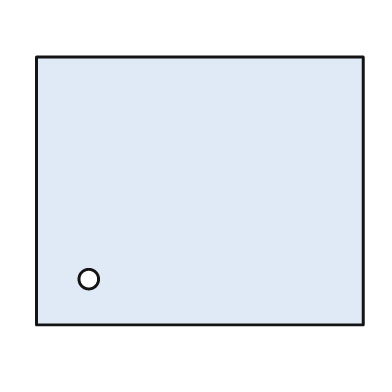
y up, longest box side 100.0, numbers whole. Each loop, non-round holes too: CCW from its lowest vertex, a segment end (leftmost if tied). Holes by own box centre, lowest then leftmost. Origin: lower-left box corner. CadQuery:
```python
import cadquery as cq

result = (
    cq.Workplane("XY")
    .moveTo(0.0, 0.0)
    .lineTo(100.0, 0.0)
    .lineTo(100.0, 82.0)
    .lineTo(0.0, 82.0)
    .close()
    .moveTo(16.0, 14.0)
    .circle(3.0)
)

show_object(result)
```